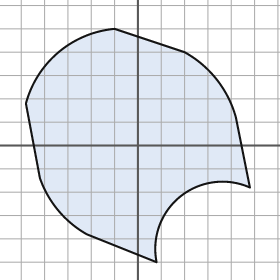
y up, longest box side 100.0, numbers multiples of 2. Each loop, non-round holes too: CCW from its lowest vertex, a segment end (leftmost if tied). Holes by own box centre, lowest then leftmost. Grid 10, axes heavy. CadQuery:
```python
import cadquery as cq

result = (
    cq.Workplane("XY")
    .moveTo(8.0, -50.0)
    .threePointArc((18.0, -22.0), (48.0, -18.0))
    .lineTo(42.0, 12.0)
    .threePointArc((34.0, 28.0), (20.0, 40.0))
    .lineTo(-10.0, 50.0)
    .threePointArc((-34.0, 40.0), (-48.0, 18.0))
    .lineTo(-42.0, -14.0)
    .threePointArc((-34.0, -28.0), (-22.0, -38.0))
    .close()
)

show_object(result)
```